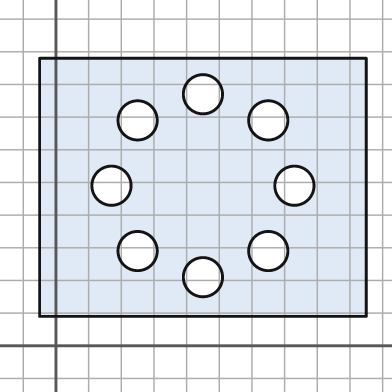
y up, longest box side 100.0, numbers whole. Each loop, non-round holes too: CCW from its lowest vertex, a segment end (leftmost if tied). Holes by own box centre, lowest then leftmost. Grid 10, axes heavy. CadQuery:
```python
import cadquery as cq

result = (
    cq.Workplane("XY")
    .moveTo(-5.0, 9.0)
    .lineTo(95.0, 9.0)
    .lineTo(95.0, 88.0)
    .lineTo(-5.0, 88.0)
    .close()
    .moveTo(45.0, 21.0)
    .circle(6.0)
    .moveTo(25.0, 29.0)
    .circle(6.0)
    .moveTo(65.0, 29.0)
    .circle(6.0)
    .moveTo(17.0, 49.0)
    .circle(6.0)
    .moveTo(73.0, 49.0)
    .circle(6.0)
    .moveTo(25.0, 69.0)
    .circle(6.0)
    .moveTo(65.0, 69.0)
    .circle(6.0)
    .moveTo(45.0, 77.0)
    .circle(6.0)
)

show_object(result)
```